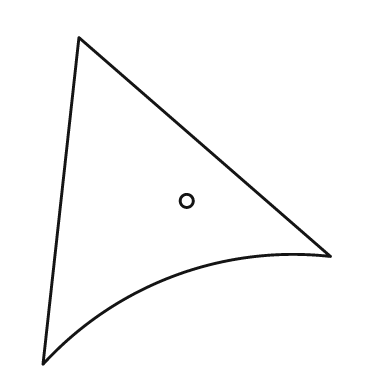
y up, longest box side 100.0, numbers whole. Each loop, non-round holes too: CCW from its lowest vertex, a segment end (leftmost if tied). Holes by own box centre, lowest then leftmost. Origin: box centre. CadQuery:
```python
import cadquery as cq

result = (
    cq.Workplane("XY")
    .moveTo(-44.0, -50.0)
    .threePointArc((-4.0, -23.0), (44.0, -17.0))
    .lineTo(-33.0, 50.0)
    .close()
    .moveTo(0.0, 0.0)
    .circle(2.0)
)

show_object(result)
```